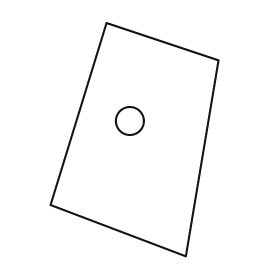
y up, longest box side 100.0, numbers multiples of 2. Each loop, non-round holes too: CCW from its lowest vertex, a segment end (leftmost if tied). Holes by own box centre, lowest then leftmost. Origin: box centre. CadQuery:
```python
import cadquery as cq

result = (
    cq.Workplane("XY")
    .moveTo(22.0, -50.0)
    .lineTo(36.0, 34.0)
    .lineTo(-12.0, 50.0)
    .lineTo(-36.0, -28.0)
    .close()
    .moveTo(-2.0, 8.0)
    .circle(6.0)
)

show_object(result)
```